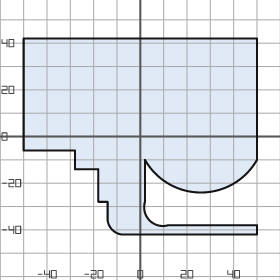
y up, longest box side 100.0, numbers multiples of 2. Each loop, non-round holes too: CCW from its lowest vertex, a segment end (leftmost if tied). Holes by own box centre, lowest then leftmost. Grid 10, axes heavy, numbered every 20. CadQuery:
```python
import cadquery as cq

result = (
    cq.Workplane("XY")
    .moveTo(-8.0, -42.0)
    .lineTo(50.0, -42.0)
    .lineTo(50.0, -38.0)
    .lineTo(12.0, -38.0)
    .threePointArc((4.0, -36.0), (2.0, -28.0))
    .lineTo(2.0, -10.0)
    .threePointArc((26.0, -24.0), (50.0, -10.0))
    .lineTo(50.0, 42.0)
    .lineTo(-50.0, 42.0)
    .lineTo(-50.0, -6.0)
    .lineTo(-28.0, -6.0)
    .lineTo(-28.0, -14.0)
    .lineTo(-18.0, -14.0)
    .lineTo(-18.0, -28.0)
    .lineTo(-14.0, -28.0)
    .lineTo(-14.0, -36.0)
    .threePointArc((-12.0, -40.0), (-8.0, -42.0))
    .close()
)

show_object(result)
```